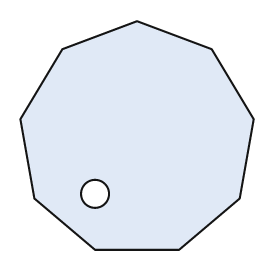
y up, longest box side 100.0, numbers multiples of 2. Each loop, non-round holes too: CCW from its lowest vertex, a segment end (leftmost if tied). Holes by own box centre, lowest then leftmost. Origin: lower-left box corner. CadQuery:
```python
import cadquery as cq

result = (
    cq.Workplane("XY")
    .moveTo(32.0, 0.0)
    .lineTo(68.0, 0.0)
    .lineTo(94.0, 22.0)
    .lineTo(100.0, 56.0)
    .lineTo(82.0, 86.0)
    .lineTo(50.0, 98.0)
    .lineTo(18.0, 86.0)
    .lineTo(0.0, 56.0)
    .lineTo(6.0, 22.0)
    .close()
    .moveTo(32.0, 24.0)
    .circle(6.0)
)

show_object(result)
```